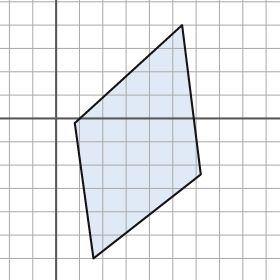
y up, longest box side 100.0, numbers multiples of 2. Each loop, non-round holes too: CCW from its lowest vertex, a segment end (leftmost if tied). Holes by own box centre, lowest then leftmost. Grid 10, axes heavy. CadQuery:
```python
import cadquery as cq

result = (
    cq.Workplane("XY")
    .moveTo(16.0, -60.0)
    .lineTo(62.0, -24.0)
    .lineTo(54.0, 40.0)
    .lineTo(8.0, -2.0)
    .close()
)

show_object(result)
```